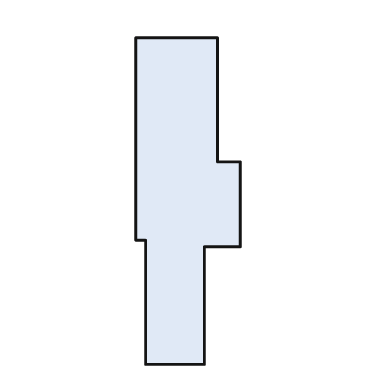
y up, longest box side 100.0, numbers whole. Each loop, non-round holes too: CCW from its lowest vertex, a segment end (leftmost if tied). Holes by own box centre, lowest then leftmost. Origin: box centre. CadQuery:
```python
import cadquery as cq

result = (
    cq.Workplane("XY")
    .moveTo(-13.0, -50.0)
    .lineTo(5.0, -50.0)
    .lineTo(5.0, -14.0)
    .lineTo(16.0, -14.0)
    .lineTo(16.0, 12.0)
    .lineTo(9.0, 12.0)
    .lineTo(9.0, 50.0)
    .lineTo(-16.0, 50.0)
    .lineTo(-16.0, -12.0)
    .lineTo(-13.0, -12.0)
    .close()
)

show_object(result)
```